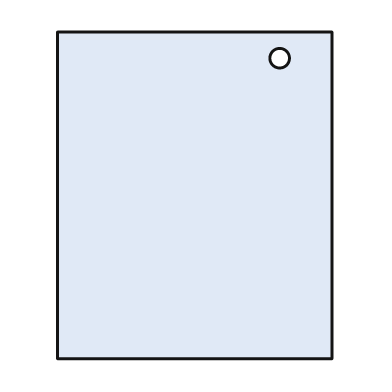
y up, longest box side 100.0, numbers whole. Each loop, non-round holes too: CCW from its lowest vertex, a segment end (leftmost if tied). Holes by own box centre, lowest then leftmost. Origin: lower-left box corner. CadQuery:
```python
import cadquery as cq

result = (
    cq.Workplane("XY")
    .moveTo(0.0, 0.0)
    .lineTo(84.0, 0.0)
    .lineTo(84.0, 100.0)
    .lineTo(0.0, 100.0)
    .close()
    .moveTo(68.0, 92.0)
    .circle(3.0)
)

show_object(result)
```